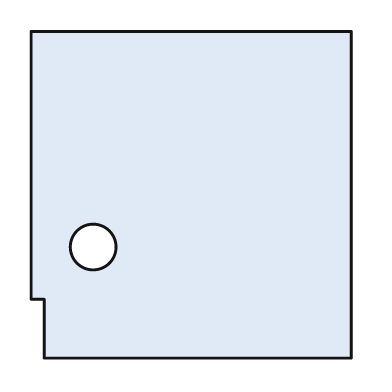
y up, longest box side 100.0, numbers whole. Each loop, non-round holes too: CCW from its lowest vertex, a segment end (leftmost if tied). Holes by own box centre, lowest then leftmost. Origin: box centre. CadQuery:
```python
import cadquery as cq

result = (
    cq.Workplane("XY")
    .moveTo(-45.0, -50.0)
    .lineTo(49.0, -50.0)
    .lineTo(49.0, 50.0)
    .lineTo(-49.0, 50.0)
    .lineTo(-49.0, -32.0)
    .lineTo(-45.0, -32.0)
    .close()
    .moveTo(-30.0, -16.0)
    .circle(7.0)
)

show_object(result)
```